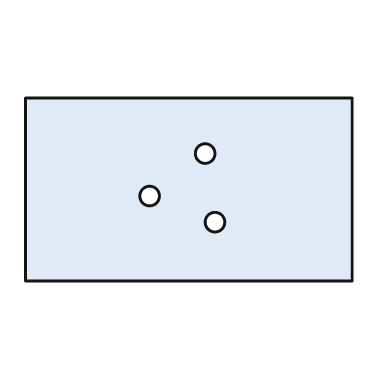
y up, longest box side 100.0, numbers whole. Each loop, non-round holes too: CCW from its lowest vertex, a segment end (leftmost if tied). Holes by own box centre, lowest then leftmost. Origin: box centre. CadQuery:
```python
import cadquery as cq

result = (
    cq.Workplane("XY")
    .moveTo(-50.0, -28.0)
    .lineTo(50.0, -28.0)
    .lineTo(50.0, 28.0)
    .lineTo(-50.0, 28.0)
    .close()
    .moveTo(8.0, -10.0)
    .circle(3.0)
    .moveTo(-12.0, -2.0)
    .circle(3.0)
    .moveTo(5.0, 11.0)
    .circle(3.0)
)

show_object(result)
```